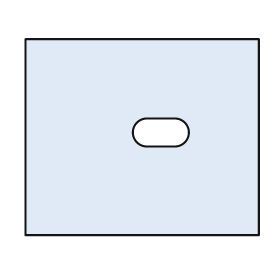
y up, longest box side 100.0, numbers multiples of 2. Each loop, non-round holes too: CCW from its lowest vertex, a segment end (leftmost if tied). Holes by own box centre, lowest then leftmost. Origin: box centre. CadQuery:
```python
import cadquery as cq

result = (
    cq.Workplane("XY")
    .moveTo(-50.0, -42.0)
    .lineTo(50.0, -42.0)
    .lineTo(50.0, 42.0)
    .lineTo(-50.0, 42.0)
    .close()
    .moveTo(2.0, -4.0)
    .lineTo(14.0, -4.0)
    .threePointArc((20.0, 2.0), (14.0, 8.0))
    .lineTo(2.0, 8.0)
    .threePointArc((-4.0, 2.0), (2.0, -4.0))
    .close()
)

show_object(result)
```